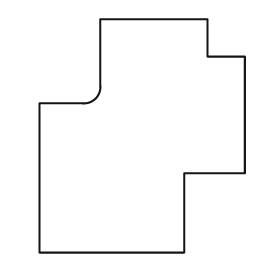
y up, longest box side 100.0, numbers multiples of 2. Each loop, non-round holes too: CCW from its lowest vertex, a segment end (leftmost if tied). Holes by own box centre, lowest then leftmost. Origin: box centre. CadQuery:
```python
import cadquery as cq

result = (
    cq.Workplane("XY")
    .moveTo(-44.0, -50.0)
    .lineTo(18.0, -50.0)
    .lineTo(18.0, -16.0)
    .lineTo(44.0, -16.0)
    .lineTo(44.0, 34.0)
    .lineTo(28.0, 34.0)
    .lineTo(28.0, 50.0)
    .lineTo(-18.0, 50.0)
    .lineTo(-18.0, 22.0)
    .threePointArc((-20.0, 16.0), (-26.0, 14.0))
    .lineTo(-44.0, 14.0)
    .close()
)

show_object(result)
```